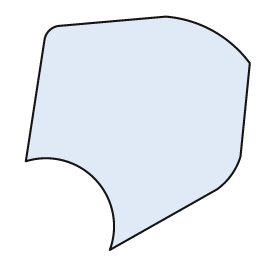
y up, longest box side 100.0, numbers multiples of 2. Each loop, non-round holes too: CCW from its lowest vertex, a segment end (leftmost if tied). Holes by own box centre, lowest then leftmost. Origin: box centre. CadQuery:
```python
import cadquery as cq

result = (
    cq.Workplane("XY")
    .moveTo(-12.0, -50.0)
    .lineTo(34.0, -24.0)
    .threePointArc((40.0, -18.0), (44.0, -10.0))
    .lineTo(48.0, 30.0)
    .threePointArc((32.0, 44.0), (12.0, 50.0))
    .lineTo(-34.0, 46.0)
    .threePointArc((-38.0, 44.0), (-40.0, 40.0))
    .lineTo(-48.0, -12.0)
    .threePointArc((-18.0, -20.0), (-12.0, -50.0))
    .close()
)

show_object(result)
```